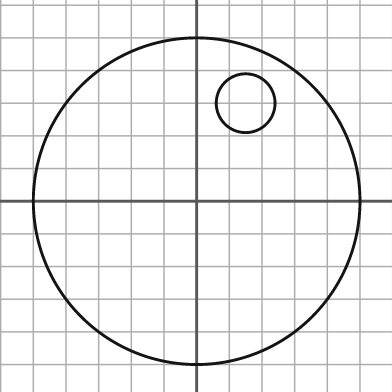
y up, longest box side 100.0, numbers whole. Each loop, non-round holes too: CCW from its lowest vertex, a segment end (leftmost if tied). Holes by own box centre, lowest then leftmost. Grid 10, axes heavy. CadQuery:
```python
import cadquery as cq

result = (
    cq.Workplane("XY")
    .moveTo(0.0, 0.0)
    .circle(50.0)
    .moveTo(15.0, 30.0)
    .circle(9.0)
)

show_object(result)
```